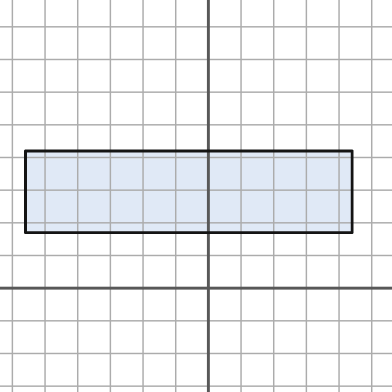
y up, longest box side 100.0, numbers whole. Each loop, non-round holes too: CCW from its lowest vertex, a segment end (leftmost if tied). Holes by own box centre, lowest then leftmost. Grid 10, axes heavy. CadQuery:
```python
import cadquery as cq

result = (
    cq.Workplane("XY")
    .moveTo(-56.0, 17.0)
    .lineTo(44.0, 17.0)
    .lineTo(44.0, 42.0)
    .lineTo(-56.0, 42.0)
    .close()
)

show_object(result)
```